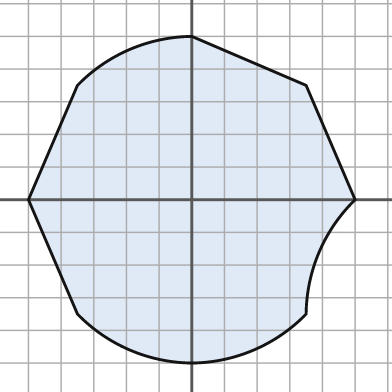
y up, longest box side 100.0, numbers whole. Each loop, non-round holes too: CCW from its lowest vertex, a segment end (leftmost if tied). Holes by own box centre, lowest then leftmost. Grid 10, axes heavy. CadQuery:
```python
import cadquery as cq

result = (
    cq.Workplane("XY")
    .moveTo(0.0, -50.0)
    .threePointArc((19.0, -46.0), (35.0, -35.0))
    .threePointArc((39.0, -16.0), (50.0, 0.0))
    .lineTo(35.0, 35.0)
    .lineTo(0.0, 50.0)
    .threePointArc((-19.0, 46.0), (-35.0, 35.0))
    .lineTo(-50.0, 0.0)
    .lineTo(-35.0, -35.0)
    .threePointArc((-19.0, -46.0), (0.0, -50.0))
    .close()
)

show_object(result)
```